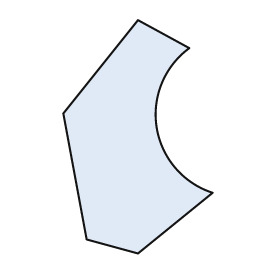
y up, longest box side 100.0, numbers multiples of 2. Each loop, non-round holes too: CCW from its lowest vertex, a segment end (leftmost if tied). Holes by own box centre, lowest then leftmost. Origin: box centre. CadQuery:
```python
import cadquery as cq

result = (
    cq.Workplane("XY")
    .moveTo(0.0, -50.0)
    .lineTo(32.0, -24.0)
    .threePointArc((8.0, 4.0), (22.0, 38.0))
    .lineTo(0.0, 50.0)
    .lineTo(-32.0, 10.0)
    .lineTo(-22.0, -44.0)
    .close()
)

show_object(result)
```